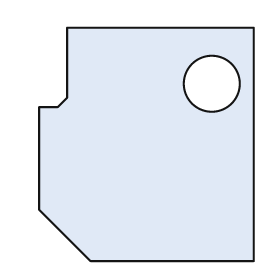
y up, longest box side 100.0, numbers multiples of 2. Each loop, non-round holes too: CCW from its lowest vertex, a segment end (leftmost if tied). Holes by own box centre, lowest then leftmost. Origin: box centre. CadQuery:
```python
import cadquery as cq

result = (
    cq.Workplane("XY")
    .moveTo(-24.0, -50.0)
    .lineTo(46.0, -50.0)
    .lineTo(46.0, 50.0)
    .lineTo(-34.0, 50.0)
    .lineTo(-34.0, 20.0)
    .lineTo(-38.0, 16.0)
    .lineTo(-46.0, 16.0)
    .lineTo(-46.0, -28.0)
    .close()
    .moveTo(28.0, 26.0)
    .circle(12.0)
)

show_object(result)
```